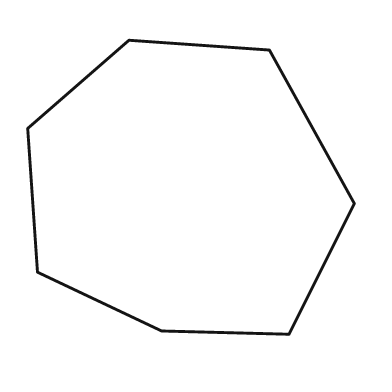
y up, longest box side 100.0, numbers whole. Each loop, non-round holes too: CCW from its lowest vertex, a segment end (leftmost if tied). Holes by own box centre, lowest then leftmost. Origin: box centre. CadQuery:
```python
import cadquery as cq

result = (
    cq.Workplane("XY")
    .moveTo(30.0, -45.0)
    .lineTo(50.0, -5.0)
    .lineTo(24.0, 42.0)
    .lineTo(-19.0, 45.0)
    .lineTo(-50.0, 18.0)
    .lineTo(-47.0, -26.0)
    .lineTo(-9.0, -44.0)
    .close()
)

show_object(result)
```